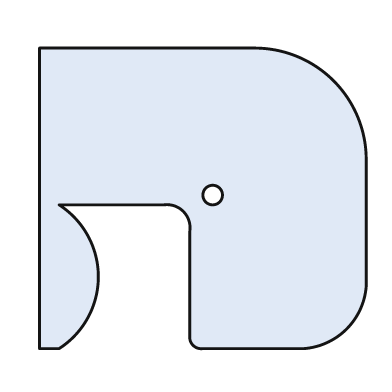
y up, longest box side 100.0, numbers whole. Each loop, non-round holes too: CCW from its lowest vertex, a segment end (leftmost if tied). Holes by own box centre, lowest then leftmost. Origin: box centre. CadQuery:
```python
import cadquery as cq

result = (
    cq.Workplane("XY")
    .moveTo(-50.0, -46.0)
    .lineTo(-44.0, -46.0)
    .threePointArc((-32.0, -24.0), (-44.0, -2.0))
    .lineTo(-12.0, -2.0)
    .threePointArc((-6.0, -4.0), (-4.0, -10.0))
    .lineTo(-4.0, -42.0)
    .threePointArc((-3.0, -45.0), (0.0, -46.0))
    .lineTo(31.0, -46.0)
    .threePointArc((44.0, -40.0), (50.0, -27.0))
    .lineTo(50.0, 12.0)
    .threePointArc((40.0, 36.0), (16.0, 46.0))
    .lineTo(-50.0, 46.0)
    .close()
    .moveTo(3.0, 1.0)
    .circle(3.0)
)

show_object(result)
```